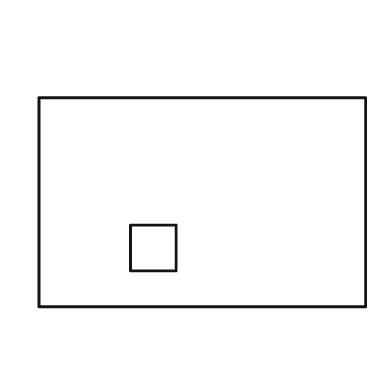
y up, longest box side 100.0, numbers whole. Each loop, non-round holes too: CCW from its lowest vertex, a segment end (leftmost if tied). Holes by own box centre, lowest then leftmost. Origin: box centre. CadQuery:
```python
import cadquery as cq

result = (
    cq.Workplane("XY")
    .moveTo(-50.0, -32.0)
    .lineTo(50.0, -32.0)
    .lineTo(50.0, 32.0)
    .lineTo(-50.0, 32.0)
    .close()
    .moveTo(-22.0, -21.0)
    .lineTo(-8.0, -21.0)
    .lineTo(-8.0, -7.0)
    .lineTo(-22.0, -7.0)
    .close()
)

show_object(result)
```